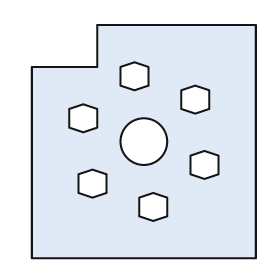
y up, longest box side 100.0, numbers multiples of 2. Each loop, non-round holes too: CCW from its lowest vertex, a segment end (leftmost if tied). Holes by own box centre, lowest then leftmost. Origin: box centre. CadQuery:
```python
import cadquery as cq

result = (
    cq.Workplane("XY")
    .moveTo(-48.0, -50.0)
    .lineTo(48.0, -50.0)
    .lineTo(48.0, 50.0)
    .lineTo(-20.0, 50.0)
    .lineTo(-20.0, 32.0)
    .lineTo(-48.0, 32.0)
    .close()
    .moveTo(4.0, -34.0)
    .lineTo(10.0, -32.0)
    .lineTo(10.0, -24.0)
    .lineTo(4.0, -22.0)
    .lineTo(-2.0, -24.0)
    .lineTo(-2.0, -32.0)
    .close()
    .moveTo(-22.0, -24.0)
    .lineTo(-16.0, -22.0)
    .lineTo(-16.0, -14.0)
    .lineTo(-22.0, -12.0)
    .lineTo(-28.0, -14.0)
    .lineTo(-28.0, -22.0)
    .close()
    .moveTo(26.0, -16.0)
    .lineTo(32.0, -14.0)
    .lineTo(32.0, -6.0)
    .lineTo(26.0, -4.0)
    .lineTo(20.0, -6.0)
    .lineTo(20.0, -14.0)
    .close()
    .moveTo(0.0, 0.0)
    .circle(10.0)
    .moveTo(-26.0, 4.0)
    .lineTo(-20.0, 6.0)
    .lineTo(-20.0, 14.0)
    .lineTo(-26.0, 16.0)
    .lineTo(-32.0, 14.0)
    .lineTo(-32.0, 6.0)
    .close()
    .moveTo(22.0, 12.0)
    .lineTo(28.0, 14.0)
    .lineTo(28.0, 22.0)
    .lineTo(22.0, 24.0)
    .lineTo(16.0, 22.0)
    .lineTo(16.0, 14.0)
    .close()
    .moveTo(-4.0, 22.0)
    .lineTo(2.0, 24.0)
    .lineTo(2.0, 32.0)
    .lineTo(-4.0, 34.0)
    .lineTo(-10.0, 32.0)
    .lineTo(-10.0, 24.0)
    .close()
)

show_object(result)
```